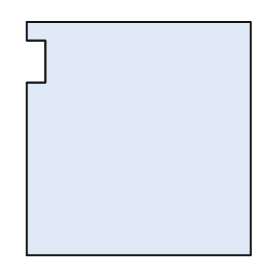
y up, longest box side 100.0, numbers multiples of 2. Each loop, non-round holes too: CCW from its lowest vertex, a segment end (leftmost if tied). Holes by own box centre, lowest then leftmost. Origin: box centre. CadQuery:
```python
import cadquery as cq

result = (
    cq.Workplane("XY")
    .moveTo(-48.0, -50.0)
    .lineTo(48.0, -50.0)
    .lineTo(48.0, 50.0)
    .lineTo(-48.0, 50.0)
    .lineTo(-48.0, 42.0)
    .lineTo(-40.0, 42.0)
    .lineTo(-40.0, 24.0)
    .lineTo(-48.0, 24.0)
    .close()
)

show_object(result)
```